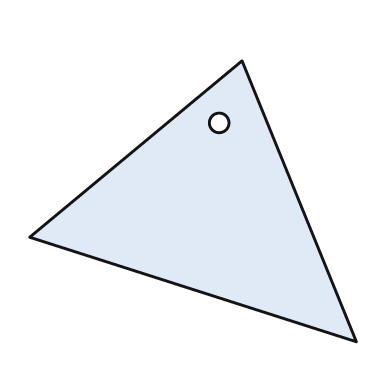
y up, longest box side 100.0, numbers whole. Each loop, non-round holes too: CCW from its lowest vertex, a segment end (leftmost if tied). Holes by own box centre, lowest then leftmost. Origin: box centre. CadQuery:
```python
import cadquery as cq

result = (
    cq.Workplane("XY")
    .moveTo(50.0, -43.0)
    .lineTo(15.0, 43.0)
    .lineTo(-50.0, -11.0)
    .close()
    .moveTo(8.0, 24.0)
    .circle(3.0)
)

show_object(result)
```